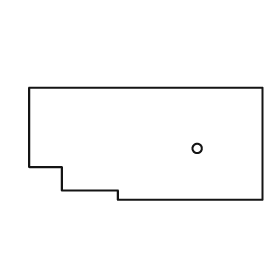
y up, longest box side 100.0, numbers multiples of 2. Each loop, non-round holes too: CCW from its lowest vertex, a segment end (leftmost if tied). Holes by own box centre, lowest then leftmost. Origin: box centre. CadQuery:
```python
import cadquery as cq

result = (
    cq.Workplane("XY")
    .moveTo(-12.0, -24.0)
    .lineTo(50.0, -24.0)
    .lineTo(50.0, 24.0)
    .lineTo(-50.0, 24.0)
    .lineTo(-50.0, -10.0)
    .lineTo(-36.0, -10.0)
    .lineTo(-36.0, -20.0)
    .lineTo(-12.0, -20.0)
    .close()
    .moveTo(22.0, -2.0)
    .circle(2.0)
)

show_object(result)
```